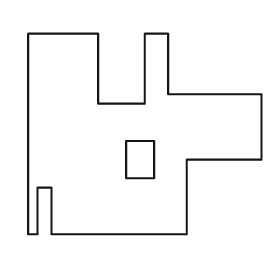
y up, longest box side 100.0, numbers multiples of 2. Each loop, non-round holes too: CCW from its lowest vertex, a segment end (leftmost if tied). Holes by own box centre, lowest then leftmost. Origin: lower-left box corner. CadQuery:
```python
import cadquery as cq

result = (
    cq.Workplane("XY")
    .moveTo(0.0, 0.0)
    .lineTo(4.0, 0.0)
    .lineTo(4.0, 20.0)
    .lineTo(10.0, 20.0)
    .lineTo(10.0, 0.0)
    .lineTo(68.0, 0.0)
    .lineTo(68.0, 32.0)
    .lineTo(100.0, 32.0)
    .lineTo(100.0, 60.0)
    .lineTo(60.0, 60.0)
    .lineTo(60.0, 86.0)
    .lineTo(50.0, 86.0)
    .lineTo(50.0, 56.0)
    .lineTo(30.0, 56.0)
    .lineTo(30.0, 86.0)
    .lineTo(0.0, 86.0)
    .close()
    .moveTo(42.0, 24.0)
    .lineTo(54.0, 24.0)
    .lineTo(54.0, 40.0)
    .lineTo(42.0, 40.0)
    .close()
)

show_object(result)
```